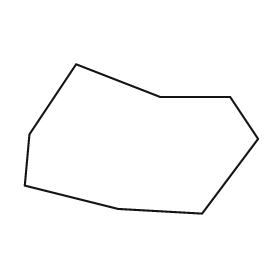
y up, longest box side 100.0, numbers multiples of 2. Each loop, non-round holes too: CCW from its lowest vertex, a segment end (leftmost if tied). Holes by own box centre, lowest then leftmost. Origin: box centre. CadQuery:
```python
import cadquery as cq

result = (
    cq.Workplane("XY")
    .moveTo(26.0, -32.0)
    .lineTo(50.0, 0.0)
    .lineTo(38.0, 18.0)
    .lineTo(8.0, 18.0)
    .lineTo(-28.0, 32.0)
    .lineTo(-48.0, 2.0)
    .lineTo(-50.0, -20.0)
    .lineTo(-10.0, -30.0)
    .close()
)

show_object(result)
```